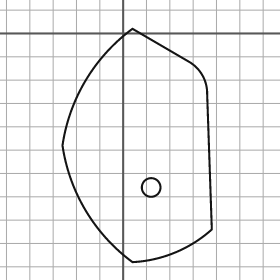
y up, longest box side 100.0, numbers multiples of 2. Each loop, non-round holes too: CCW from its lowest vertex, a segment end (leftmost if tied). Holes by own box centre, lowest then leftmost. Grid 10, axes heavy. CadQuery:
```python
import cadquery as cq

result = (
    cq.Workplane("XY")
    .moveTo(4.0, -98.0)
    .threePointArc((22.0, -94.0), (38.0, -84.0))
    .lineTo(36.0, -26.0)
    .threePointArc((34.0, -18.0), (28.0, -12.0))
    .lineTo(4.0, 2.0)
    .threePointArc((-16.0, -20.0), (-26.0, -48.0))
    .threePointArc((-16.0, -76.0), (4.0, -98.0))
    .close()
    .moveTo(12.0, -66.0)
    .circle(4.0)
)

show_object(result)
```